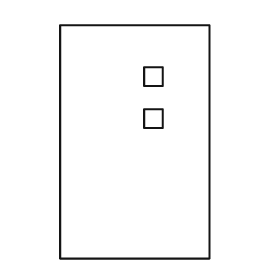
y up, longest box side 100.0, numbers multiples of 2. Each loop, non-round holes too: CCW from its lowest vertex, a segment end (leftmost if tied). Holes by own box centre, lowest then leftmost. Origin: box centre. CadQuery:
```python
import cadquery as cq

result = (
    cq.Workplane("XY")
    .moveTo(-32.0, -50.0)
    .lineTo(32.0, -50.0)
    .lineTo(32.0, 50.0)
    .lineTo(-32.0, 50.0)
    .close()
    .moveTo(4.0, 6.0)
    .lineTo(12.0, 6.0)
    .lineTo(12.0, 14.0)
    .lineTo(4.0, 14.0)
    .close()
    .moveTo(4.0, 24.0)
    .lineTo(12.0, 24.0)
    .lineTo(12.0, 32.0)
    .lineTo(4.0, 32.0)
    .close()
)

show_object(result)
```